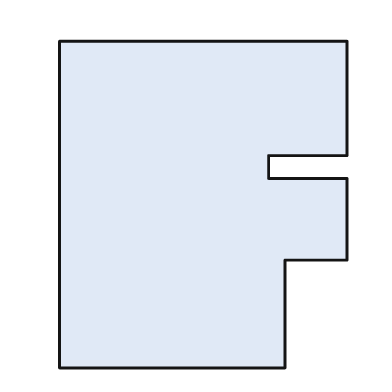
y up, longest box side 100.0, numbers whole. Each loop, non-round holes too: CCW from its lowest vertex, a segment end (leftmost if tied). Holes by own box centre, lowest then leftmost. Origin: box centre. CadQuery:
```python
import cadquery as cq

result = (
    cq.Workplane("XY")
    .moveTo(-44.0, -50.0)
    .lineTo(25.0, -50.0)
    .lineTo(25.0, -17.0)
    .lineTo(44.0, -17.0)
    .lineTo(44.0, 8.0)
    .lineTo(20.0, 8.0)
    .lineTo(20.0, 15.0)
    .lineTo(44.0, 15.0)
    .lineTo(44.0, 50.0)
    .lineTo(-44.0, 50.0)
    .close()
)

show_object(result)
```